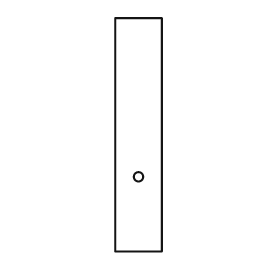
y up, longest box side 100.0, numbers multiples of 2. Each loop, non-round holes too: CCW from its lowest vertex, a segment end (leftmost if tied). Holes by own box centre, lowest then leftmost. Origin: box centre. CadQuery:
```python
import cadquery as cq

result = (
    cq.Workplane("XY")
    .moveTo(-10.0, -50.0)
    .lineTo(10.0, -50.0)
    .lineTo(10.0, 50.0)
    .lineTo(-10.0, 50.0)
    .close()
    .moveTo(0.0, -18.0)
    .circle(2.0)
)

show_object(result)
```